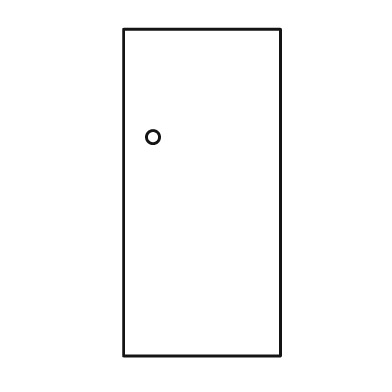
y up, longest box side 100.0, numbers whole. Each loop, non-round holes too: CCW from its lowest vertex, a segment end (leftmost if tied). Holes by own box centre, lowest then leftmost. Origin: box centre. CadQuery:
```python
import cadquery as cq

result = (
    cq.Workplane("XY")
    .moveTo(-24.0, -50.0)
    .lineTo(24.0, -50.0)
    .lineTo(24.0, 50.0)
    .lineTo(-24.0, 50.0)
    .close()
    .moveTo(-15.0, 17.0)
    .circle(2.0)
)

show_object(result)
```